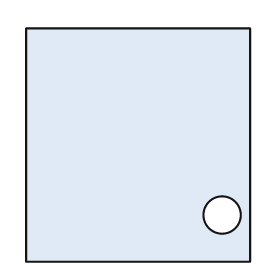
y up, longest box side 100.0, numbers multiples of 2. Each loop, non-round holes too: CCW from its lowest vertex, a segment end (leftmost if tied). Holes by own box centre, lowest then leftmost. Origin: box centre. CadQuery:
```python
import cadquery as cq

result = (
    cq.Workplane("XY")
    .moveTo(-48.0, -50.0)
    .lineTo(48.0, -50.0)
    .lineTo(48.0, 50.0)
    .lineTo(-48.0, 50.0)
    .close()
    .moveTo(36.0, -30.0)
    .circle(8.0)
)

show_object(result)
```